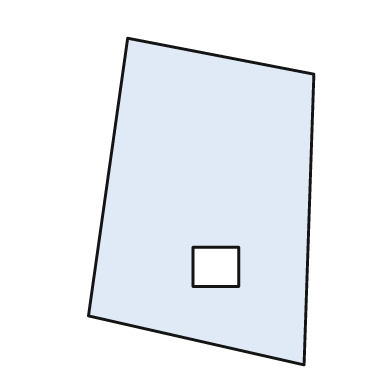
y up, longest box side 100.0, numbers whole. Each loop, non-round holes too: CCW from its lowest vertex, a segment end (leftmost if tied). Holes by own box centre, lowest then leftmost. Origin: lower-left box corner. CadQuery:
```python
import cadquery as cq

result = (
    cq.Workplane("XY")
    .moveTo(66.0, 0.0)
    .lineTo(69.0, 89.0)
    .lineTo(12.0, 100.0)
    .lineTo(0.0, 15.0)
    .close()
    .moveTo(32.0, 24.0)
    .lineTo(46.0, 24.0)
    .lineTo(46.0, 36.0)
    .lineTo(32.0, 36.0)
    .close()
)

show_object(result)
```